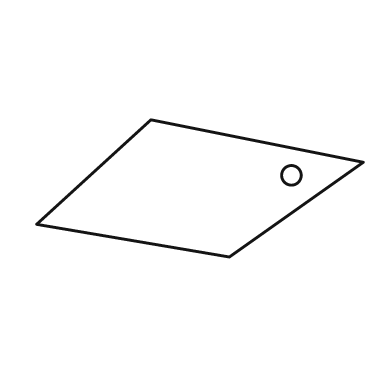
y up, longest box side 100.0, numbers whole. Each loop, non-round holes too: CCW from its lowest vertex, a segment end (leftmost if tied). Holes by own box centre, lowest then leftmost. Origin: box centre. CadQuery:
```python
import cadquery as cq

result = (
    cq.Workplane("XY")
    .moveTo(9.0, -21.0)
    .lineTo(50.0, 8.0)
    .lineTo(-15.0, 21.0)
    .lineTo(-50.0, -11.0)
    .close()
    .moveTo(28.0, 4.0)
    .circle(3.0)
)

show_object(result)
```